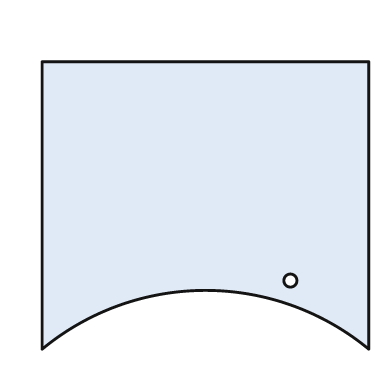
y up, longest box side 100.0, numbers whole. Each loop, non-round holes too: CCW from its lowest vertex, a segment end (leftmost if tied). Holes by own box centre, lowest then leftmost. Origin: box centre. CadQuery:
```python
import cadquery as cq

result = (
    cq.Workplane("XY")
    .moveTo(-50.0, -44.0)
    .threePointArc((0.0, -26.0), (50.0, -44.0))
    .lineTo(50.0, 44.0)
    .lineTo(-50.0, 44.0)
    .close()
    .moveTo(26.0, -23.0)
    .circle(2.0)
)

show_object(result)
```